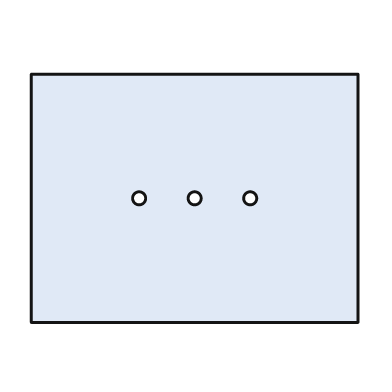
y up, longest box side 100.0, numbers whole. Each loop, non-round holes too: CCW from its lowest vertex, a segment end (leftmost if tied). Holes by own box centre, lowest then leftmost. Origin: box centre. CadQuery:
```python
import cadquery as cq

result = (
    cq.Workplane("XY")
    .moveTo(-50.0, -38.0)
    .lineTo(50.0, -38.0)
    .lineTo(50.0, 38.0)
    .lineTo(-50.0, 38.0)
    .close()
    .moveTo(-17.0, 0.0)
    .circle(2.0)
    .moveTo(0.0, 0.0)
    .circle(2.0)
    .moveTo(17.0, 0.0)
    .circle(2.0)
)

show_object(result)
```